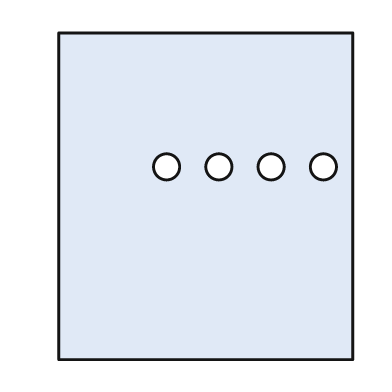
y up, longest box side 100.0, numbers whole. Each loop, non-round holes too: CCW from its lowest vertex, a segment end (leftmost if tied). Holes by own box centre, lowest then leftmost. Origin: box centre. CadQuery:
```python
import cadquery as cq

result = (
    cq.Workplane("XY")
    .moveTo(-45.0, -50.0)
    .lineTo(45.0, -50.0)
    .lineTo(45.0, 50.0)
    .lineTo(-45.0, 50.0)
    .close()
    .moveTo(-12.0, 9.0)
    .circle(4.0)
    .moveTo(4.0, 9.0)
    .circle(4.0)
    .moveTo(20.0, 9.0)
    .circle(4.0)
    .moveTo(36.0, 9.0)
    .circle(4.0)
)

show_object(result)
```